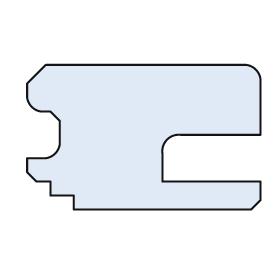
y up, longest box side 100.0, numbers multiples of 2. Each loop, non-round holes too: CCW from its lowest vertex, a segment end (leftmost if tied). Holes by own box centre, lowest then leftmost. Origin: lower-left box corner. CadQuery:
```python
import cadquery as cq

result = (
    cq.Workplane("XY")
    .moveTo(20.0, 0.0)
    .lineTo(96.0, 0.0)
    .lineTo(100.0, 4.0)
    .lineTo(100.0, 12.0)
    .lineTo(58.0, 12.0)
    .lineTo(58.0, 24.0)
    .threePointArc((60.0, 30.0), (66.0, 32.0))
    .lineTo(100.0, 32.0)
    .lineTo(100.0, 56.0)
    .threePointArc((98.0, 60.0), (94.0, 62.0))
    .lineTo(8.0, 62.0)
    .lineTo(0.0, 54.0)
    .lineTo(0.0, 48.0)
    .threePointArc((2.0, 44.0), (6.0, 42.0))
    .lineTo(10.0, 42.0)
    .lineTo(14.0, 38.0)
    .lineTo(14.0, 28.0)
    .threePointArc((12.0, 24.0), (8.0, 22.0))
    .lineTo(0.0, 22.0)
    .lineTo(0.0, 16.0)
    .lineTo(4.0, 12.0)
    .lineTo(10.0, 12.0)
    .lineTo(10.0, 6.0)
    .lineTo(20.0, 6.0)
    .close()
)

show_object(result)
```